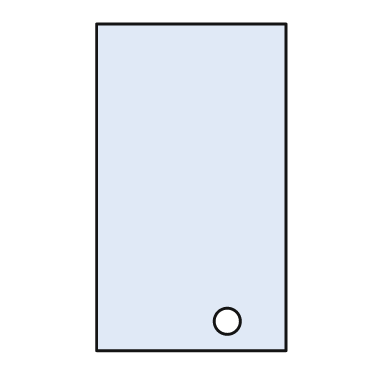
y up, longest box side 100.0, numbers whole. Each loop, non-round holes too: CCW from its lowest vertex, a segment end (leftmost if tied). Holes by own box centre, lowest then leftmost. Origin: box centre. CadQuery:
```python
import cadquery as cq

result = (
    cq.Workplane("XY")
    .moveTo(-29.0, -50.0)
    .lineTo(29.0, -50.0)
    .lineTo(29.0, 50.0)
    .lineTo(-29.0, 50.0)
    .close()
    .moveTo(11.0, -41.0)
    .circle(4.0)
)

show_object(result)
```